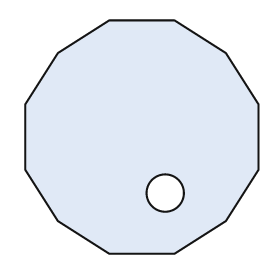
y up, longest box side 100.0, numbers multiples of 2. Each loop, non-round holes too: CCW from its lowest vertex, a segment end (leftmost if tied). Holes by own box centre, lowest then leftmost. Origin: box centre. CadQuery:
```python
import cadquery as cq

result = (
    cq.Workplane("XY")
    .moveTo(-14.0, -50.0)
    .lineTo(14.0, -50.0)
    .lineTo(36.0, -36.0)
    .lineTo(50.0, -14.0)
    .lineTo(50.0, 14.0)
    .lineTo(36.0, 36.0)
    .lineTo(14.0, 50.0)
    .lineTo(-14.0, 50.0)
    .lineTo(-36.0, 36.0)
    .lineTo(-50.0, 14.0)
    .lineTo(-50.0, -14.0)
    .lineTo(-36.0, -36.0)
    .close()
    .moveTo(10.0, -24.0)
    .circle(8.0)
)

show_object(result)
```